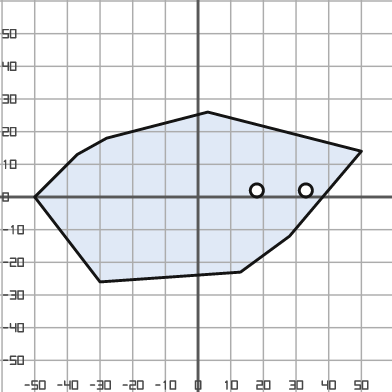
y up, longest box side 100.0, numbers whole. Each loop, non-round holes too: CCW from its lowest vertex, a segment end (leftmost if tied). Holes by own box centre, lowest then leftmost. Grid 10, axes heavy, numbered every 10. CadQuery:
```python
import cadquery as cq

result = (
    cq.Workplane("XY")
    .moveTo(-30.0, -26.0)
    .lineTo(13.0, -23.0)
    .lineTo(28.0, -12.0)
    .lineTo(50.0, 14.0)
    .lineTo(3.0, 26.0)
    .lineTo(-28.0, 18.0)
    .lineTo(-37.0, 13.0)
    .lineTo(-50.0, 0.0)
    .close()
    .moveTo(18.0, 2.0)
    .circle(2.0)
    .moveTo(33.0, 2.0)
    .circle(2.0)
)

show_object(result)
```